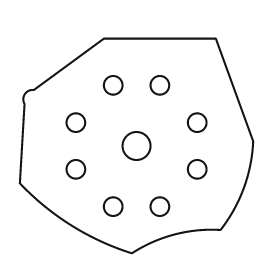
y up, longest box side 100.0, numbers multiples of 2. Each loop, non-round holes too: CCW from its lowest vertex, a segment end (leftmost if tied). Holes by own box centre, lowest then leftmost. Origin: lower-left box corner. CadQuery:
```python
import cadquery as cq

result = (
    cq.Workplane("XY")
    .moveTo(48.0, 0.0)
    .threePointArc((66.0, 8.0), (86.0, 10.0))
    .threePointArc((96.0, 28.0), (100.0, 48.0))
    .lineTo(84.0, 92.0)
    .lineTo(36.0, 92.0)
    .lineTo(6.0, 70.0)
    .threePointArc((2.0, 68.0), (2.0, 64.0))
    .lineTo(0.0, 30.0)
    .threePointArc((22.0, 12.0), (48.0, 0.0))
    .close()
    .moveTo(40.0, 20.0)
    .circle(4.0)
    .moveTo(60.0, 20.0)
    .circle(4.0)
    .moveTo(24.0, 36.0)
    .circle(4.0)
    .moveTo(76.0, 36.0)
    .circle(4.0)
    .moveTo(50.0, 46.0)
    .circle(6.0)
    .moveTo(24.0, 56.0)
    .circle(4.0)
    .moveTo(76.0, 56.0)
    .circle(4.0)
    .moveTo(40.0, 72.0)
    .circle(4.0)
    .moveTo(60.0, 72.0)
    .circle(4.0)
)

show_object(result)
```